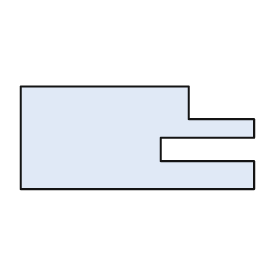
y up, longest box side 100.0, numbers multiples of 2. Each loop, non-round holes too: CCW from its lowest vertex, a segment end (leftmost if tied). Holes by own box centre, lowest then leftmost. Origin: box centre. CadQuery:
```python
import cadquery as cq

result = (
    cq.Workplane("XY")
    .moveTo(-50.0, -22.0)
    .lineTo(50.0, -22.0)
    .lineTo(50.0, -10.0)
    .lineTo(10.0, -10.0)
    .lineTo(10.0, 0.0)
    .lineTo(50.0, 0.0)
    .lineTo(50.0, 8.0)
    .lineTo(22.0, 8.0)
    .lineTo(22.0, 22.0)
    .lineTo(-50.0, 22.0)
    .close()
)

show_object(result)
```